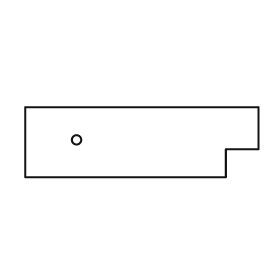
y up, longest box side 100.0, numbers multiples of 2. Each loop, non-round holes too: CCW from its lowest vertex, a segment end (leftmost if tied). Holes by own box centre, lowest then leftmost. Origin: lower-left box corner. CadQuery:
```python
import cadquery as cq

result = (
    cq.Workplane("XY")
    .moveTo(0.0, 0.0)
    .lineTo(86.0, 0.0)
    .lineTo(86.0, 12.0)
    .lineTo(100.0, 12.0)
    .lineTo(100.0, 30.0)
    .lineTo(0.0, 30.0)
    .close()
    .moveTo(22.0, 16.0)
    .circle(2.0)
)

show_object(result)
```